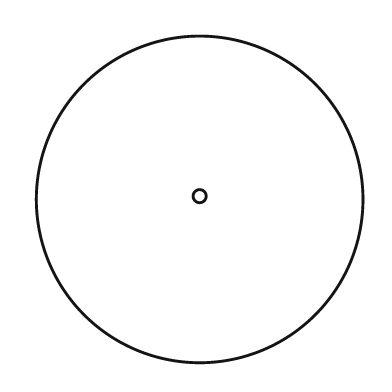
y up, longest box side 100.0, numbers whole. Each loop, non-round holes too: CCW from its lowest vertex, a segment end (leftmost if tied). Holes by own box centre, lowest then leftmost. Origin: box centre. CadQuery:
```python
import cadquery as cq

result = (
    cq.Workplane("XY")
    .moveTo(0.0, 0.0)
    .circle(50.0)
    .moveTo(0.0, 1.0)
    .circle(2.0)
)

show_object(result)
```